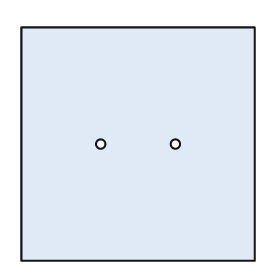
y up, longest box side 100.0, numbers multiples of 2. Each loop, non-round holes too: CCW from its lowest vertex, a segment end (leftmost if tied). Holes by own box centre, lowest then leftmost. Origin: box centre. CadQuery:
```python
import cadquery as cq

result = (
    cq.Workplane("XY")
    .moveTo(-50.0, -50.0)
    .lineTo(50.0, -50.0)
    .lineTo(50.0, 50.0)
    .lineTo(-50.0, 50.0)
    .close()
    .moveTo(-16.0, 0.0)
    .circle(2.0)
    .moveTo(16.0, 0.0)
    .circle(2.0)
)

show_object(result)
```